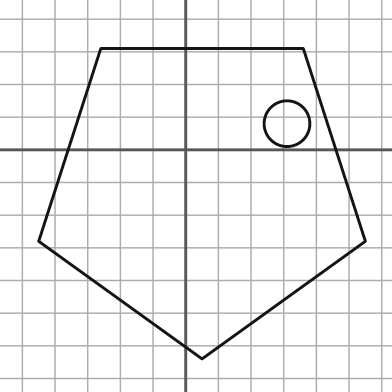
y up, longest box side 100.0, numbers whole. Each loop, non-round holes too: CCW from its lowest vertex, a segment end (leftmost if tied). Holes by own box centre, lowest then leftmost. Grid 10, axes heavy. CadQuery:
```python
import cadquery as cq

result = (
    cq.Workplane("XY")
    .moveTo(5.0, -64.0)
    .lineTo(55.0, -28.0)
    .lineTo(36.0, 31.0)
    .lineTo(-26.0, 31.0)
    .lineTo(-45.0, -28.0)
    .close()
    .moveTo(31.0, 8.0)
    .circle(7.0)
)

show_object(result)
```